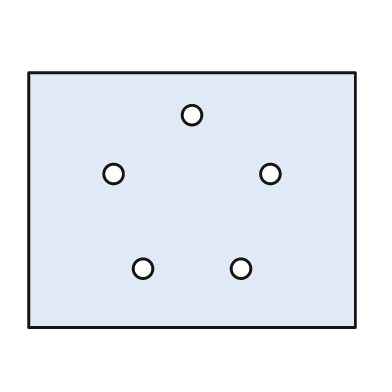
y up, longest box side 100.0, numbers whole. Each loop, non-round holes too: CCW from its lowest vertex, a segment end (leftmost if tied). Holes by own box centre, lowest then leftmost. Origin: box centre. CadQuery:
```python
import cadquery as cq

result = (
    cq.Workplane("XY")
    .moveTo(-50.0, -39.0)
    .lineTo(50.0, -39.0)
    .lineTo(50.0, 39.0)
    .lineTo(-50.0, 39.0)
    .close()
    .moveTo(-15.0, -21.0)
    .circle(3.0)
    .moveTo(15.0, -21.0)
    .circle(3.0)
    .moveTo(-24.0, 8.0)
    .circle(3.0)
    .moveTo(24.0, 8.0)
    .circle(3.0)
    .moveTo(0.0, 26.0)
    .circle(3.0)
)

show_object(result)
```